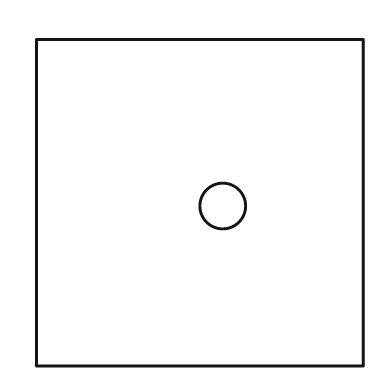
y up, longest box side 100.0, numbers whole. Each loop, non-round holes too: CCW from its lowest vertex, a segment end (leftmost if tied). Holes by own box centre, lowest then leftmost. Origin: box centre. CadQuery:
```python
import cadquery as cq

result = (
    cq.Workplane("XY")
    .moveTo(-50.0, -50.0)
    .lineTo(50.0, -50.0)
    .lineTo(50.0, 50.0)
    .lineTo(-50.0, 50.0)
    .close()
    .moveTo(7.0, -1.0)
    .circle(7.0)
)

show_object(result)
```